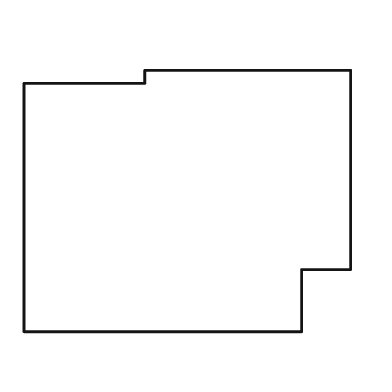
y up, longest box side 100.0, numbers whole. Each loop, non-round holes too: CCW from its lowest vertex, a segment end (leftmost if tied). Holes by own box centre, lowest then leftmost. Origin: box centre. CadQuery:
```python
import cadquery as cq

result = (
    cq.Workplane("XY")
    .moveTo(-50.0, -40.0)
    .lineTo(35.0, -40.0)
    .lineTo(35.0, -21.0)
    .lineTo(50.0, -21.0)
    .lineTo(50.0, 40.0)
    .lineTo(-13.0, 40.0)
    .lineTo(-13.0, 36.0)
    .lineTo(-50.0, 36.0)
    .close()
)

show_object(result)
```